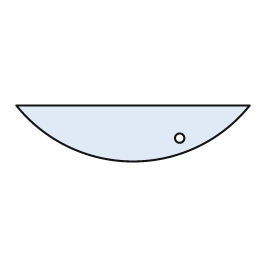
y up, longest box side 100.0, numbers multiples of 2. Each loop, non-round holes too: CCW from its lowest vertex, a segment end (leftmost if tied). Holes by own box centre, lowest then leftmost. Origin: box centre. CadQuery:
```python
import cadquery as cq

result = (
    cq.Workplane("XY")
    .moveTo(-50.0, 12.0)
    .threePointArc((0.0, -12.0), (50.0, 12.0))
    .close()
    .moveTo(20.0, -2.0)
    .circle(2.0)
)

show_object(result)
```